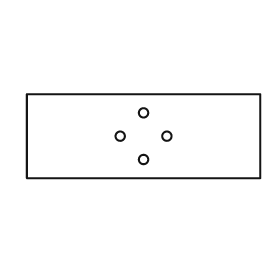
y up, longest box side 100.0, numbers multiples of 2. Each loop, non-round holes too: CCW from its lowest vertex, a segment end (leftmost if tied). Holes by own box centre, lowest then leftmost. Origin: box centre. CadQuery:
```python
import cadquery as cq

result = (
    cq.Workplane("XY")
    .moveTo(-50.0, -18.0)
    .lineTo(50.0, -18.0)
    .lineTo(50.0, 18.0)
    .lineTo(-50.0, 18.0)
    .close()
    .moveTo(0.0, -10.0)
    .circle(2.0)
    .moveTo(-10.0, 0.0)
    .circle(2.0)
    .moveTo(10.0, 0.0)
    .circle(2.0)
    .moveTo(0.0, 10.0)
    .circle(2.0)
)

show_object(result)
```